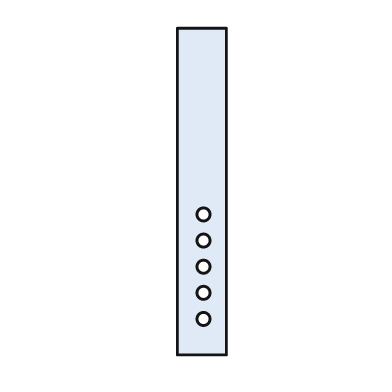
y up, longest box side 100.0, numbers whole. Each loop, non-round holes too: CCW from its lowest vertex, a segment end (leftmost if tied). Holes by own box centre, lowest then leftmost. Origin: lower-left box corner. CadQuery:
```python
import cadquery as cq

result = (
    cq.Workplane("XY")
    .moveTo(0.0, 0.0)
    .lineTo(15.0, 0.0)
    .lineTo(15.0, 100.0)
    .lineTo(0.0, 100.0)
    .close()
    .moveTo(8.0, 11.0)
    .circle(2.0)
    .moveTo(8.0, 19.0)
    .circle(2.0)
    .moveTo(8.0, 27.0)
    .circle(2.0)
    .moveTo(8.0, 35.0)
    .circle(2.0)
    .moveTo(8.0, 43.0)
    .circle(2.0)
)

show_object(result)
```